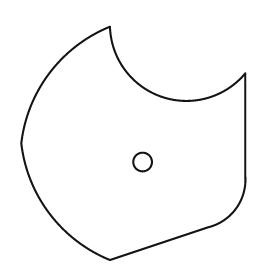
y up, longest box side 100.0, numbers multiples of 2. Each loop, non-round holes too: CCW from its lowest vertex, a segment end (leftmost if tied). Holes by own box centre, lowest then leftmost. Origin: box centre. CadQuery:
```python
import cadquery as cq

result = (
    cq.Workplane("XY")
    .moveTo(-10.0, -50.0)
    .lineTo(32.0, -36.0)
    .threePointArc((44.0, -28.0), (48.0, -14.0))
    .lineTo(48.0, 30.0)
    .threePointArc((12.0, 20.0), (-10.0, 50.0))
    .threePointArc((-36.0, 30.0), (-48.0, 0.0))
    .threePointArc((-36.0, -30.0), (-10.0, -50.0))
    .close()
    .moveTo(4.0, -8.0)
    .circle(4.0)
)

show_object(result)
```